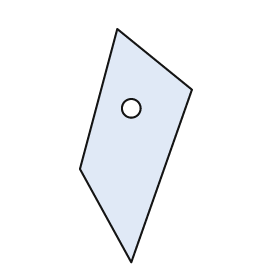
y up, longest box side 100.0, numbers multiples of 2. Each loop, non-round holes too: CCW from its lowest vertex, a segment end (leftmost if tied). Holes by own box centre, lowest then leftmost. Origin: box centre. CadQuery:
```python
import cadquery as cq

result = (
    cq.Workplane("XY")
    .moveTo(-2.0, -50.0)
    .lineTo(24.0, 24.0)
    .lineTo(-8.0, 50.0)
    .lineTo(-24.0, -10.0)
    .close()
    .moveTo(-2.0, 16.0)
    .circle(4.0)
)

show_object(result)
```